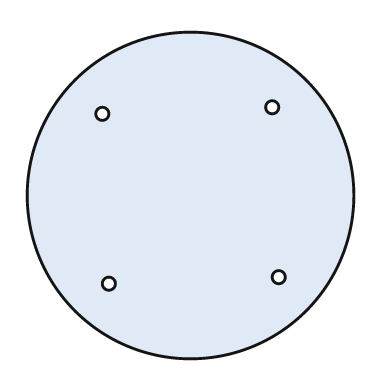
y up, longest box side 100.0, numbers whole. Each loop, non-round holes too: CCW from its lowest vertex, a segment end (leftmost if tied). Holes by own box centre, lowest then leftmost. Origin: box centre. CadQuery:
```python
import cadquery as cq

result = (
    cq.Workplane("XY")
    .moveTo(0.0, 0.0)
    .circle(50.0)
    .moveTo(-25.0, -27.0)
    .circle(2.0)
    .moveTo(27.0, -25.0)
    .circle(2.0)
    .moveTo(-27.0, 25.0)
    .circle(2.0)
    .moveTo(25.0, 27.0)
    .circle(2.0)
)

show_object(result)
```